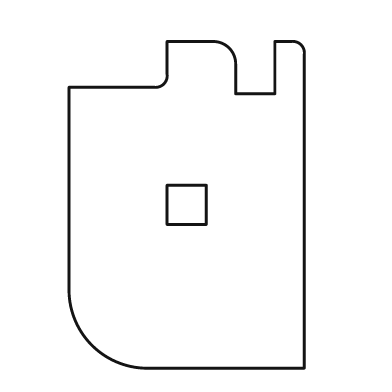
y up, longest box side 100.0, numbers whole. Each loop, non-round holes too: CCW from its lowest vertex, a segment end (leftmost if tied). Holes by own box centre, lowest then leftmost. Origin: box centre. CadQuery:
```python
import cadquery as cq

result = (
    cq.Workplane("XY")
    .moveTo(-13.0, -50.0)
    .lineTo(36.0, -50.0)
    .lineTo(36.0, 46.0)
    .threePointArc((35.0, 49.0), (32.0, 50.0))
    .lineTo(27.0, 50.0)
    .lineTo(27.0, 34.0)
    .lineTo(15.0, 34.0)
    .lineTo(15.0, 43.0)
    .threePointArc((13.0, 48.0), (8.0, 50.0))
    .lineTo(-6.0, 50.0)
    .lineTo(-6.0, 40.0)
    .threePointArc((-7.0, 37.0), (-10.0, 36.0))
    .lineTo(-36.0, 36.0)
    .lineTo(-36.0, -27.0)
    .threePointArc((-29.0, -43.0), (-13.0, -50.0))
    .close()
    .moveTo(-6.0, -6.0)
    .lineTo(6.0, -6.0)
    .lineTo(6.0, 6.0)
    .lineTo(-6.0, 6.0)
    .close()
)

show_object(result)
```